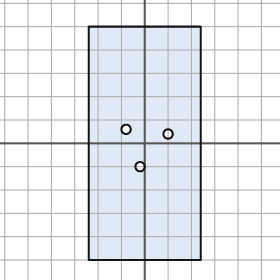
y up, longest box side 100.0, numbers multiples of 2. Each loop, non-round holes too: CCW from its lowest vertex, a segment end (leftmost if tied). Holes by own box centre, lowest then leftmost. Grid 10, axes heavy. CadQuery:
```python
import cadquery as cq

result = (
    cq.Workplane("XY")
    .moveTo(-24.0, -50.0)
    .lineTo(24.0, -50.0)
    .lineTo(24.0, 50.0)
    .lineTo(-24.0, 50.0)
    .close()
    .moveTo(-2.0, -10.0)
    .circle(2.0)
    .moveTo(10.0, 4.0)
    .circle(2.0)
    .moveTo(-8.0, 6.0)
    .circle(2.0)
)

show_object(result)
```